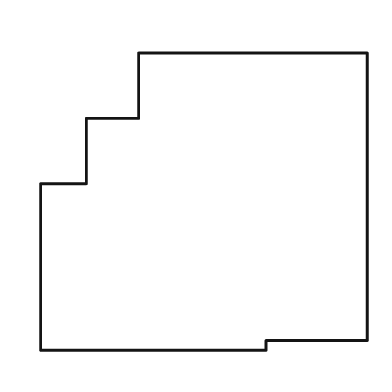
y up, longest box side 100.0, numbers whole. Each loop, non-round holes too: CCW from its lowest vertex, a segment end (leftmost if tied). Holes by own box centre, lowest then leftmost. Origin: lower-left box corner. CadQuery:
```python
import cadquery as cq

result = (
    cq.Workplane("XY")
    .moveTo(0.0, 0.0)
    .lineTo(69.0, 0.0)
    .lineTo(69.0, 3.0)
    .lineTo(100.0, 3.0)
    .lineTo(100.0, 91.0)
    .lineTo(30.0, 91.0)
    .lineTo(30.0, 71.0)
    .lineTo(14.0, 71.0)
    .lineTo(14.0, 51.0)
    .lineTo(0.0, 51.0)
    .close()
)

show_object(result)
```